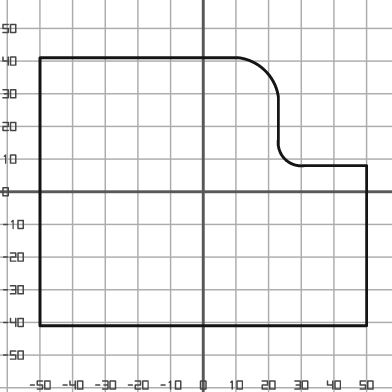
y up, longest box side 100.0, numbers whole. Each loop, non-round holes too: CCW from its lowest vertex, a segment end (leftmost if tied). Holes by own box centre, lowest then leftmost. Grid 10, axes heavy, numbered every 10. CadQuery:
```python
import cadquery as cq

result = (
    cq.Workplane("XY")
    .moveTo(-50.0, -41.0)
    .lineTo(50.0, -41.0)
    .lineTo(50.0, 8.0)
    .lineTo(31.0, 8.0)
    .threePointArc((25.0, 10.0), (23.0, 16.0))
    .lineTo(23.0, 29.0)
    .threePointArc((19.0, 37.0), (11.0, 41.0))
    .lineTo(-50.0, 41.0)
    .close()
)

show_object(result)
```